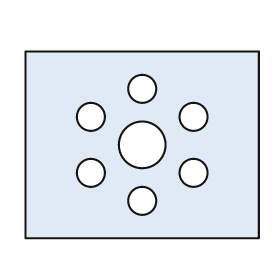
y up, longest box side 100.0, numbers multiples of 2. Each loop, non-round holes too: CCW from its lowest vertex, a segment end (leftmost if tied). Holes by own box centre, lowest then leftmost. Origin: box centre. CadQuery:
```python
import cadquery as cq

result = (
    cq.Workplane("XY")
    .moveTo(-50.0, -40.0)
    .lineTo(50.0, -40.0)
    .lineTo(50.0, 40.0)
    .lineTo(-50.0, 40.0)
    .close()
    .moveTo(0.0, -24.0)
    .circle(6.0)
    .moveTo(-22.0, -12.0)
    .circle(6.0)
    .moveTo(22.0, -12.0)
    .circle(6.0)
    .moveTo(0.0, 0.0)
    .circle(10.0)
    .moveTo(-22.0, 12.0)
    .circle(6.0)
    .moveTo(22.0, 12.0)
    .circle(6.0)
    .moveTo(0.0, 24.0)
    .circle(6.0)
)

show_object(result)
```